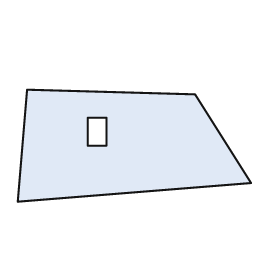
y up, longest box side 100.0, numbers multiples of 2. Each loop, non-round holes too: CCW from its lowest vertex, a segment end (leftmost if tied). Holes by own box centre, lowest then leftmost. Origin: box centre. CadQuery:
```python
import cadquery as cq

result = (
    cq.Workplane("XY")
    .moveTo(-50.0, -24.0)
    .lineTo(50.0, -16.0)
    .lineTo(26.0, 22.0)
    .lineTo(-46.0, 24.0)
    .close()
    .moveTo(-20.0, 0.0)
    .lineTo(-12.0, 0.0)
    .lineTo(-12.0, 12.0)
    .lineTo(-20.0, 12.0)
    .close()
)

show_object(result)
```